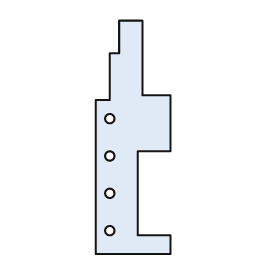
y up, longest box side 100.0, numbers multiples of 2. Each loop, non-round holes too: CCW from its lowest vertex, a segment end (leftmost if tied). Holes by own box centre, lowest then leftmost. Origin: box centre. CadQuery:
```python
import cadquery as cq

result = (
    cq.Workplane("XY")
    .moveTo(-16.0, -50.0)
    .lineTo(16.0, -50.0)
    .lineTo(16.0, -42.0)
    .lineTo(2.0, -42.0)
    .lineTo(2.0, -6.0)
    .lineTo(16.0, -6.0)
    .lineTo(16.0, 18.0)
    .lineTo(4.0, 18.0)
    .lineTo(4.0, 50.0)
    .lineTo(-6.0, 50.0)
    .lineTo(-6.0, 36.0)
    .lineTo(-10.0, 36.0)
    .lineTo(-10.0, 16.0)
    .lineTo(-16.0, 16.0)
    .close()
    .moveTo(-10.0, -40.0)
    .circle(2.0)
    .moveTo(-10.0, -24.0)
    .circle(2.0)
    .moveTo(-10.0, -8.0)
    .circle(2.0)
    .moveTo(-10.0, 8.0)
    .circle(2.0)
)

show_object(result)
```